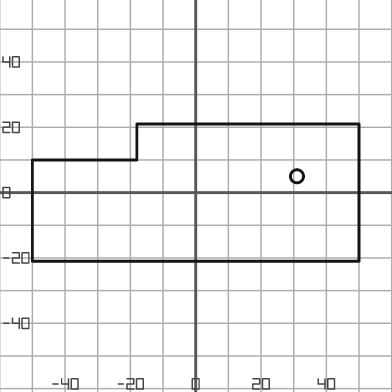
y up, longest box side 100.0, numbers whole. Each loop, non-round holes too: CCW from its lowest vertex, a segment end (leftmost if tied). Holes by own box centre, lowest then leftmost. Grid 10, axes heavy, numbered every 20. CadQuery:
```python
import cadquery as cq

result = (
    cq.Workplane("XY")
    .moveTo(-50.0, -21.0)
    .lineTo(50.0, -21.0)
    .lineTo(50.0, 21.0)
    .lineTo(-18.0, 21.0)
    .lineTo(-18.0, 10.0)
    .lineTo(-50.0, 10.0)
    .close()
    .moveTo(31.0, 5.0)
    .circle(2.0)
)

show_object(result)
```